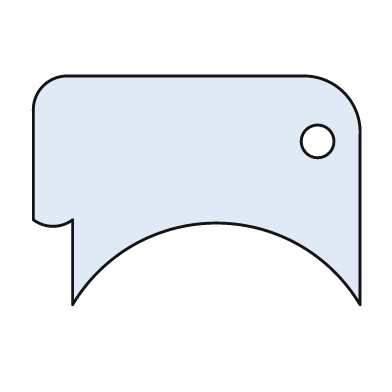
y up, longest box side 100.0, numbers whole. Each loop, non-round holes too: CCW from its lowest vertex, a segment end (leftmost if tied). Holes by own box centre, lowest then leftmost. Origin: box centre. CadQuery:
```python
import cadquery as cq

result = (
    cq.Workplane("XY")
    .moveTo(-38.0, -35.0)
    .threePointArc((6.0, -10.0), (50.0, -35.0))
    .lineTo(50.0, 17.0)
    .threePointArc((45.0, 30.0), (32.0, 35.0))
    .lineTo(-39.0, 35.0)
    .threePointArc((-47.0, 32.0), (-50.0, 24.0))
    .lineTo(-50.0, -9.0)
    .threePointArc((-44.0, -11.0), (-38.0, -9.0))
    .close()
    .moveTo(37.0, 15.0)
    .circle(5.0)
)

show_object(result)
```